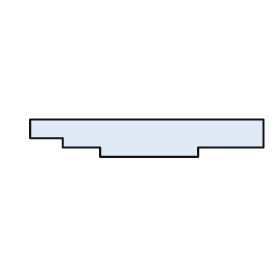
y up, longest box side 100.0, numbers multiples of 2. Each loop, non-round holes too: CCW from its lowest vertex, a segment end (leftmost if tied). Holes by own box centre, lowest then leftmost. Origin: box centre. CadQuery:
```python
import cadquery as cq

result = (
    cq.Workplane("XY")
    .moveTo(-20.0, -8.0)
    .lineTo(22.0, -8.0)
    .lineTo(22.0, -4.0)
    .lineTo(50.0, -4.0)
    .lineTo(50.0, 8.0)
    .lineTo(-50.0, 8.0)
    .lineTo(-50.0, 0.0)
    .lineTo(-36.0, 0.0)
    .lineTo(-36.0, -4.0)
    .lineTo(-20.0, -4.0)
    .close()
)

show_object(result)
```